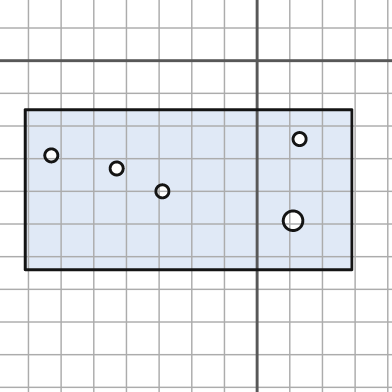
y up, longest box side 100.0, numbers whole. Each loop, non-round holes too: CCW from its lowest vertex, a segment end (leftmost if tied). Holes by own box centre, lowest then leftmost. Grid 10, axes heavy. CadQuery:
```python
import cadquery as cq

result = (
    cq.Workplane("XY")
    .moveTo(-71.0, -64.0)
    .lineTo(29.0, -64.0)
    .lineTo(29.0, -15.0)
    .lineTo(-71.0, -15.0)
    .close()
    .moveTo(11.0, -49.0)
    .circle(3.0)
    .moveTo(-29.0, -40.0)
    .circle(2.0)
    .moveTo(-43.0, -33.0)
    .circle(2.0)
    .moveTo(-63.0, -29.0)
    .circle(2.0)
    .moveTo(13.0, -24.0)
    .circle(2.0)
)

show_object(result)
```